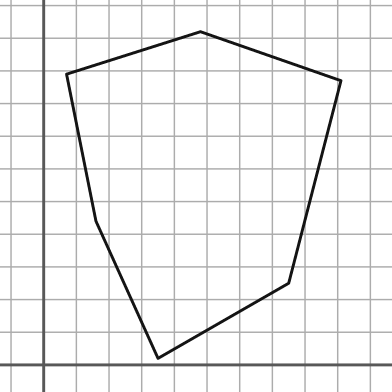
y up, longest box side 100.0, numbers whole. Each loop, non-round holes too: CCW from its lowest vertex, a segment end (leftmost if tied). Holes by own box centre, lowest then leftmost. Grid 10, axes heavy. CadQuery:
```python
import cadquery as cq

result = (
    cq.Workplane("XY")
    .moveTo(35.0, 2.0)
    .lineTo(75.0, 25.0)
    .lineTo(91.0, 87.0)
    .lineTo(48.0, 102.0)
    .lineTo(7.0, 89.0)
    .lineTo(16.0, 44.0)
    .close()
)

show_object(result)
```